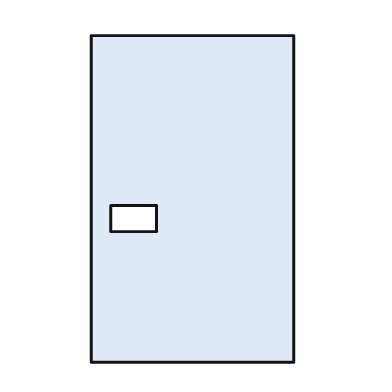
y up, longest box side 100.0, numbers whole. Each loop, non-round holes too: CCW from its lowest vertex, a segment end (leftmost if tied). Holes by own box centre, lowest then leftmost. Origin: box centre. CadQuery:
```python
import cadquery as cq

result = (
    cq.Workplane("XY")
    .moveTo(-31.0, -50.0)
    .lineTo(31.0, -50.0)
    .lineTo(31.0, 50.0)
    .lineTo(-31.0, 50.0)
    .close()
    .moveTo(-25.0, -10.0)
    .lineTo(-11.0, -10.0)
    .lineTo(-11.0, -2.0)
    .lineTo(-25.0, -2.0)
    .close()
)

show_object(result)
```